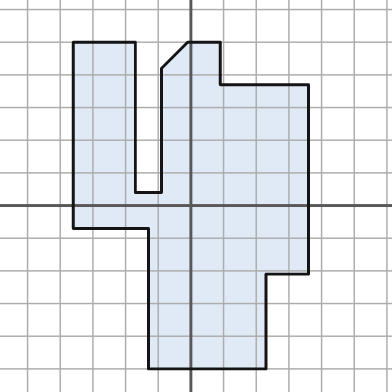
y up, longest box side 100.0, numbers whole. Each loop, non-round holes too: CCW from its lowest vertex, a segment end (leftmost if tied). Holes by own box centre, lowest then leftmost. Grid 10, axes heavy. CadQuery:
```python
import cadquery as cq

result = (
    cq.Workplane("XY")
    .moveTo(-13.0, -50.0)
    .lineTo(23.0, -50.0)
    .lineTo(23.0, -21.0)
    .lineTo(36.0, -21.0)
    .lineTo(36.0, 37.0)
    .lineTo(9.0, 37.0)
    .lineTo(9.0, 50.0)
    .lineTo(-1.0, 50.0)
    .lineTo(-9.0, 42.0)
    .lineTo(-9.0, 4.0)
    .lineTo(-17.0, 4.0)
    .lineTo(-17.0, 50.0)
    .lineTo(-36.0, 50.0)
    .lineTo(-36.0, -7.0)
    .lineTo(-13.0, -7.0)
    .close()
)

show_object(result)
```